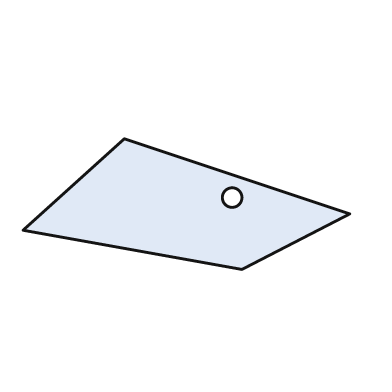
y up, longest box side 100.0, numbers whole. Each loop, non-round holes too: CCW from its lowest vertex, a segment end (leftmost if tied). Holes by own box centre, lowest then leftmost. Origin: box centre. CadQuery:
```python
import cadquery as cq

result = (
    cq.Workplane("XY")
    .moveTo(17.0, -20.0)
    .lineTo(50.0, -3.0)
    .lineTo(-19.0, 20.0)
    .lineTo(-50.0, -8.0)
    .close()
    .moveTo(14.0, 2.0)
    .circle(3.0)
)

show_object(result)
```